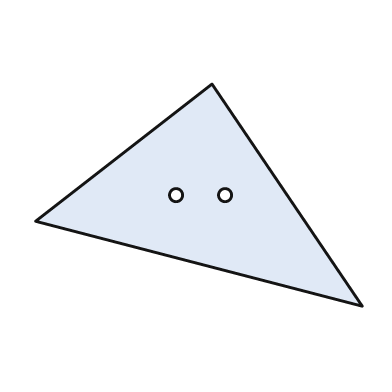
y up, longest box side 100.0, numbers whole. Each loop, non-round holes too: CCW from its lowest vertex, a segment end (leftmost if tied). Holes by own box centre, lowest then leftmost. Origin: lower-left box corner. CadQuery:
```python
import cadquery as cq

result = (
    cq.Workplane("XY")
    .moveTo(100.0, 0.0)
    .lineTo(54.0, 68.0)
    .lineTo(0.0, 26.0)
    .close()
    .moveTo(43.0, 34.0)
    .circle(2.0)
    .moveTo(58.0, 34.0)
    .circle(2.0)
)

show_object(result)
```